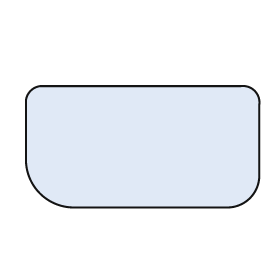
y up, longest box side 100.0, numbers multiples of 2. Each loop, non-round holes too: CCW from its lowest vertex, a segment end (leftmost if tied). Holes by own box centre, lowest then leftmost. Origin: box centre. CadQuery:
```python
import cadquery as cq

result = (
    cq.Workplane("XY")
    .moveTo(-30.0, -26.0)
    .lineTo(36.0, -26.0)
    .threePointArc((46.0, -22.0), (50.0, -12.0))
    .lineTo(50.0, 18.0)
    .threePointArc((48.0, 24.0), (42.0, 26.0))
    .lineTo(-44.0, 26.0)
    .threePointArc((-48.0, 24.0), (-50.0, 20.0))
    .lineTo(-50.0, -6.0)
    .threePointArc((-44.0, -20.0), (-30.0, -26.0))
    .close()
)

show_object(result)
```